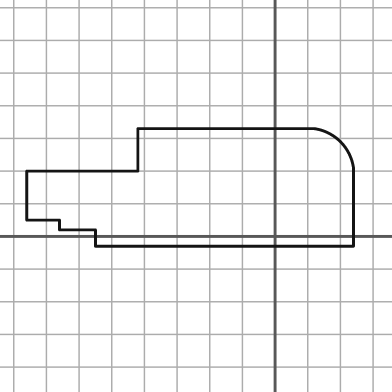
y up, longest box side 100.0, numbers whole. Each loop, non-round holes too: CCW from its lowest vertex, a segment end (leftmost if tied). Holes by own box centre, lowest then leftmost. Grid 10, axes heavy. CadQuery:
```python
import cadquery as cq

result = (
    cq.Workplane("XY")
    .moveTo(-55.0, -3.0)
    .lineTo(24.0, -3.0)
    .lineTo(24.0, 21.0)
    .threePointArc((20.0, 29.0), (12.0, 33.0))
    .lineTo(-42.0, 33.0)
    .lineTo(-42.0, 20.0)
    .lineTo(-76.0, 20.0)
    .lineTo(-76.0, 5.0)
    .lineTo(-66.0, 5.0)
    .lineTo(-66.0, 2.0)
    .lineTo(-55.0, 2.0)
    .close()
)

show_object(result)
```